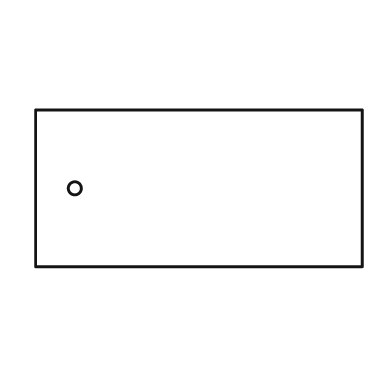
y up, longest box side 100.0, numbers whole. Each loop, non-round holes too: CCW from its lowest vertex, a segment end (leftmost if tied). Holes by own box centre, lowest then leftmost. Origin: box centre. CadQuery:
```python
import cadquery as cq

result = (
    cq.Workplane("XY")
    .moveTo(-50.0, -24.0)
    .lineTo(50.0, -24.0)
    .lineTo(50.0, 24.0)
    .lineTo(-50.0, 24.0)
    .close()
    .moveTo(-38.0, 0.0)
    .circle(2.0)
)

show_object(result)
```